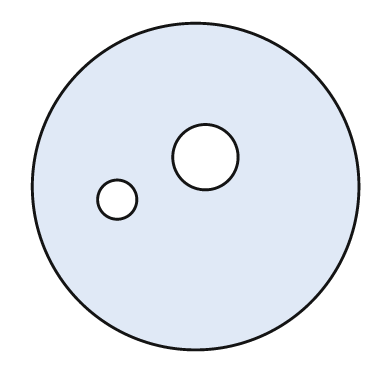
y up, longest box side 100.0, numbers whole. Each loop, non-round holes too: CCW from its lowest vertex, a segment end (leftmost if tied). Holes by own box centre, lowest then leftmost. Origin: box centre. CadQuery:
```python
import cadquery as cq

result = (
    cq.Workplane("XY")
    .moveTo(0.0, 0.0)
    .circle(50.0)
    .moveTo(-24.0, -4.0)
    .circle(6.0)
    .moveTo(3.0, 9.0)
    .circle(10.0)
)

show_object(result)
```